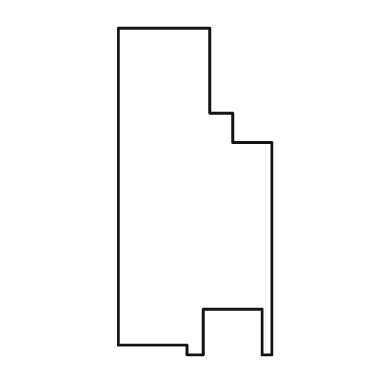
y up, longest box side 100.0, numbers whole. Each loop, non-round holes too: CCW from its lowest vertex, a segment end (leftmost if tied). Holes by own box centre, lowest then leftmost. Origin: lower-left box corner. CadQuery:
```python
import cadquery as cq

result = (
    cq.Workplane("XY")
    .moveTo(21.0, 0.0)
    .lineTo(26.0, 0.0)
    .lineTo(26.0, 14.0)
    .lineTo(44.0, 14.0)
    .lineTo(44.0, 0.0)
    .lineTo(47.0, 0.0)
    .lineTo(47.0, 65.0)
    .lineTo(35.0, 65.0)
    .lineTo(35.0, 74.0)
    .lineTo(28.0, 74.0)
    .lineTo(28.0, 100.0)
    .lineTo(0.0, 100.0)
    .lineTo(0.0, 3.0)
    .lineTo(21.0, 3.0)
    .close()
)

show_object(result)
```